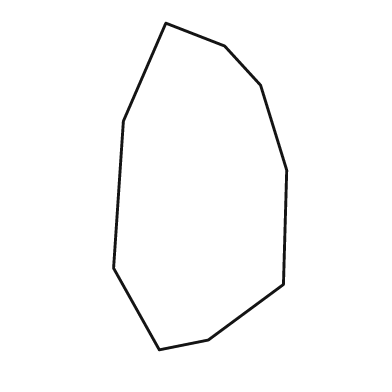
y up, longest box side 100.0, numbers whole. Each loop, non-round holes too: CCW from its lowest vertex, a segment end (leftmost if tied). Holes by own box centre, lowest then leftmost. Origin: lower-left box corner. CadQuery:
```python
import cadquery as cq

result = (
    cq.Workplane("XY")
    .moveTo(14.0, 0.0)
    .lineTo(29.0, 3.0)
    .lineTo(52.0, 20.0)
    .lineTo(53.0, 55.0)
    .lineTo(45.0, 81.0)
    .lineTo(34.0, 93.0)
    .lineTo(16.0, 100.0)
    .lineTo(3.0, 70.0)
    .lineTo(0.0, 25.0)
    .close()
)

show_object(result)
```